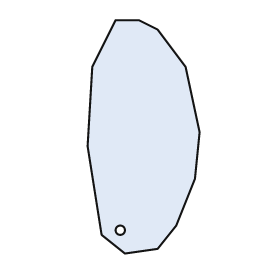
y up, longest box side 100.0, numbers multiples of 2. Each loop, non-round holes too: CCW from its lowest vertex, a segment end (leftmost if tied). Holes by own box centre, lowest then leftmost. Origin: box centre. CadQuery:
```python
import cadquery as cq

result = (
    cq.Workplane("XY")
    .moveTo(-8.0, -50.0)
    .lineTo(6.0, -48.0)
    .lineTo(14.0, -38.0)
    .lineTo(22.0, -18.0)
    .lineTo(24.0, 2.0)
    .lineTo(18.0, 30.0)
    .lineTo(6.0, 46.0)
    .lineTo(-2.0, 50.0)
    .lineTo(-12.0, 50.0)
    .lineTo(-22.0, 30.0)
    .lineTo(-24.0, -4.0)
    .lineTo(-18.0, -42.0)
    .close()
    .moveTo(-10.0, -40.0)
    .circle(2.0)
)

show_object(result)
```